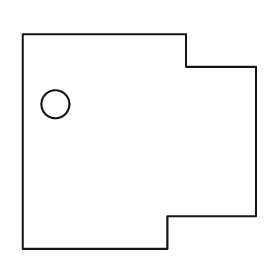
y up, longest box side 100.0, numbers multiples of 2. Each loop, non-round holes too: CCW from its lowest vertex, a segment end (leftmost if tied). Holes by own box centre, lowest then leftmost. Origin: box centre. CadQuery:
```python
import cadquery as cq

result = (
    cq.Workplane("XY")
    .moveTo(-50.0, -46.0)
    .lineTo(12.0, -46.0)
    .lineTo(12.0, -32.0)
    .lineTo(50.0, -32.0)
    .lineTo(50.0, 32.0)
    .lineTo(20.0, 32.0)
    .lineTo(20.0, 46.0)
    .lineTo(-50.0, 46.0)
    .close()
    .moveTo(-36.0, 16.0)
    .circle(6.0)
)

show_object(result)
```